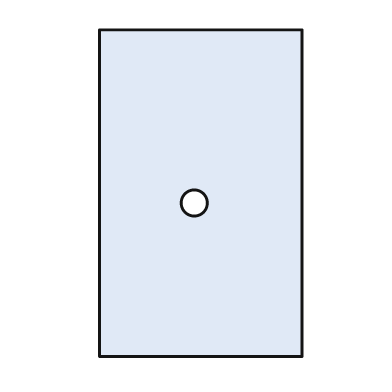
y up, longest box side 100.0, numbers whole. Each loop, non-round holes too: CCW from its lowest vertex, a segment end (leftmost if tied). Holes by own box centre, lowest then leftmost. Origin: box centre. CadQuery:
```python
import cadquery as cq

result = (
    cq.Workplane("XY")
    .moveTo(-31.0, -50.0)
    .lineTo(31.0, -50.0)
    .lineTo(31.0, 50.0)
    .lineTo(-31.0, 50.0)
    .close()
    .moveTo(-2.0, -3.0)
    .circle(4.0)
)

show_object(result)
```